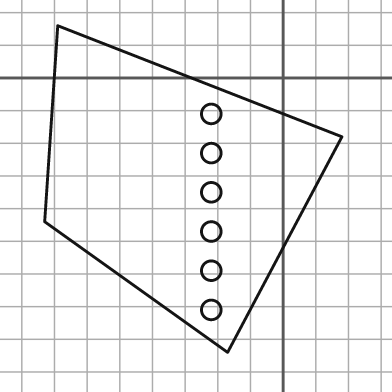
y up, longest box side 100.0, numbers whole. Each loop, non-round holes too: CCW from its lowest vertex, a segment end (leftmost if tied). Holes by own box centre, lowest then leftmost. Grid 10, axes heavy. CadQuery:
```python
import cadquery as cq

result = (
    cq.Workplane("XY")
    .moveTo(-17.0, -84.0)
    .lineTo(18.0, -18.0)
    .lineTo(-69.0, 16.0)
    .lineTo(-73.0, -44.0)
    .close()
    .moveTo(-22.0, -71.0)
    .circle(3.0)
    .moveTo(-22.0, -59.0)
    .circle(3.0)
    .moveTo(-22.0, -47.0)
    .circle(3.0)
    .moveTo(-22.0, -35.0)
    .circle(3.0)
    .moveTo(-22.0, -23.0)
    .circle(3.0)
    .moveTo(-22.0, -11.0)
    .circle(3.0)
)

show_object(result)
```